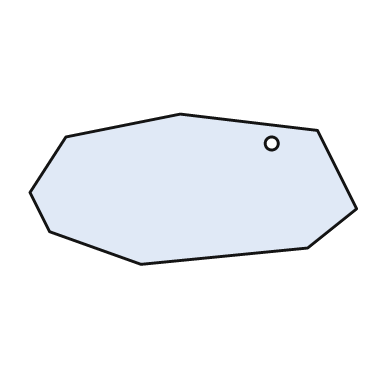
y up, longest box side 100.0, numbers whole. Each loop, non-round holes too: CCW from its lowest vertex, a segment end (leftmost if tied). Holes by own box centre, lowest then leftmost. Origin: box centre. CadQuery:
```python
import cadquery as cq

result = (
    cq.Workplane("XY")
    .moveTo(-16.0, -23.0)
    .lineTo(35.0, -18.0)
    .lineTo(50.0, -6.0)
    .lineTo(38.0, 18.0)
    .lineTo(-4.0, 23.0)
    .lineTo(-39.0, 16.0)
    .lineTo(-50.0, -1.0)
    .lineTo(-44.0, -13.0)
    .close()
    .moveTo(24.0, 14.0)
    .circle(2.0)
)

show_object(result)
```